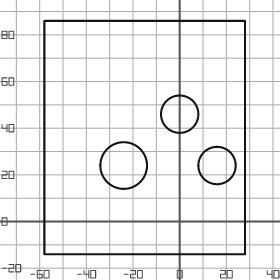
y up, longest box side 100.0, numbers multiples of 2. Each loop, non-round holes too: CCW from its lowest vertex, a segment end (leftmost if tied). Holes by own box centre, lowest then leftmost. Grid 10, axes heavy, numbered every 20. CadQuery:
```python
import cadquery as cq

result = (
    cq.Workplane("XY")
    .moveTo(-58.0, -14.0)
    .lineTo(28.0, -14.0)
    .lineTo(28.0, 86.0)
    .lineTo(-58.0, 86.0)
    .close()
    .moveTo(-24.0, 24.0)
    .circle(10.0)
    .moveTo(16.0, 24.0)
    .circle(8.0)
    .moveTo(0.0, 46.0)
    .circle(8.0)
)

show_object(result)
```